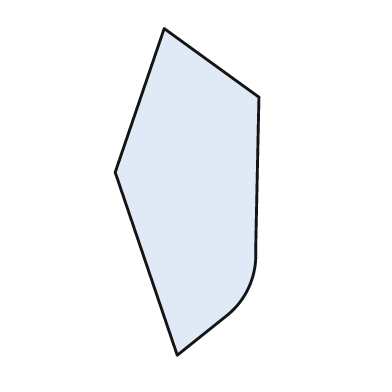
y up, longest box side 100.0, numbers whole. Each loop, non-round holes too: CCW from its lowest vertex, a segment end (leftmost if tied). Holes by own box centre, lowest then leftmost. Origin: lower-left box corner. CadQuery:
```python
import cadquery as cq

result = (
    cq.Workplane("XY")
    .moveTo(19.0, 0.0)
    .lineTo(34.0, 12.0)
    .threePointArc((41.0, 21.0), (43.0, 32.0))
    .lineTo(44.0, 79.0)
    .lineTo(15.0, 100.0)
    .lineTo(0.0, 56.0)
    .close()
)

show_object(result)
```